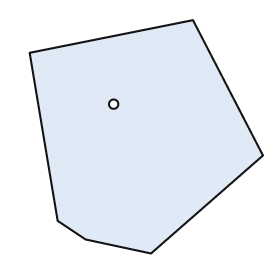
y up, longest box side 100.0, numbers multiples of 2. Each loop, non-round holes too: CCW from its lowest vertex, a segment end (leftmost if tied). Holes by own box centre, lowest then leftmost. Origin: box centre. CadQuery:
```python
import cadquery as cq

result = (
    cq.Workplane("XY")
    .moveTo(2.0, -50.0)
    .lineTo(50.0, -8.0)
    .lineTo(20.0, 50.0)
    .lineTo(-50.0, 36.0)
    .lineTo(-38.0, -36.0)
    .lineTo(-26.0, -44.0)
    .close()
    .moveTo(-14.0, 14.0)
    .circle(2.0)
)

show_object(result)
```